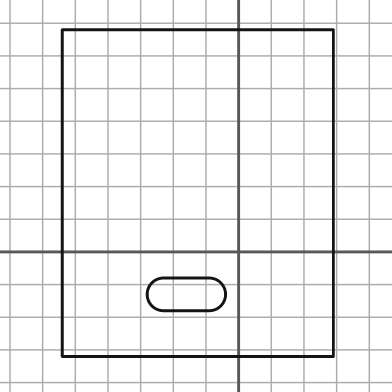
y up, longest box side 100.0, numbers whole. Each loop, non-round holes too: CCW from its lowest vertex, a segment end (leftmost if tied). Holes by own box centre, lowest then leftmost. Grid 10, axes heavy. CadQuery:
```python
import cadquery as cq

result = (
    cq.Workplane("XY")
    .moveTo(-54.0, -32.0)
    .lineTo(29.0, -32.0)
    .lineTo(29.0, 68.0)
    .lineTo(-54.0, 68.0)
    .close()
    .moveTo(-23.0, -18.0)
    .lineTo(-9.0, -18.0)
    .threePointArc((-4.0, -13.0), (-9.0, -8.0))
    .lineTo(-23.0, -8.0)
    .threePointArc((-28.0, -13.0), (-23.0, -18.0))
    .close()
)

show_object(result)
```